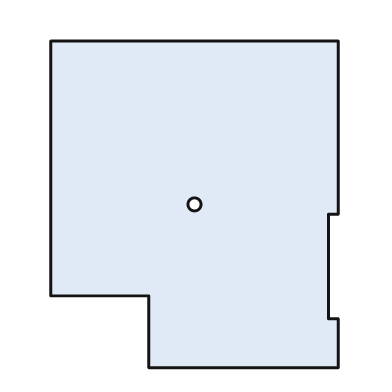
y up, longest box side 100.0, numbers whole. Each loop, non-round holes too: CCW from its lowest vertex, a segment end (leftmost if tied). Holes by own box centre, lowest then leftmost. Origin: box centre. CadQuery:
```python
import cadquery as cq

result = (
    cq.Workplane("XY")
    .moveTo(-14.0, -50.0)
    .lineTo(44.0, -50.0)
    .lineTo(44.0, -35.0)
    .lineTo(41.0, -35.0)
    .lineTo(41.0, -3.0)
    .lineTo(44.0, -3.0)
    .lineTo(44.0, 50.0)
    .lineTo(-44.0, 50.0)
    .lineTo(-44.0, -28.0)
    .lineTo(-14.0, -28.0)
    .close()
    .moveTo(0.0, 0.0)
    .circle(2.0)
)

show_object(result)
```